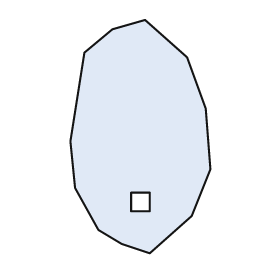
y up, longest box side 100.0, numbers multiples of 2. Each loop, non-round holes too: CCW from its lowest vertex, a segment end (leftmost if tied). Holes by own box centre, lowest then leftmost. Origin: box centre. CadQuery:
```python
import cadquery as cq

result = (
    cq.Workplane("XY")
    .moveTo(4.0, -50.0)
    .lineTo(22.0, -34.0)
    .lineTo(30.0, -14.0)
    .lineTo(28.0, 12.0)
    .lineTo(20.0, 34.0)
    .lineTo(2.0, 50.0)
    .lineTo(-12.0, 46.0)
    .lineTo(-24.0, 36.0)
    .lineTo(-30.0, -2.0)
    .lineTo(-28.0, -22.0)
    .lineTo(-18.0, -40.0)
    .lineTo(-8.0, -46.0)
    .close()
    .moveTo(-4.0, -32.0)
    .lineTo(4.0, -32.0)
    .lineTo(4.0, -24.0)
    .lineTo(-4.0, -24.0)
    .close()
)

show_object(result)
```